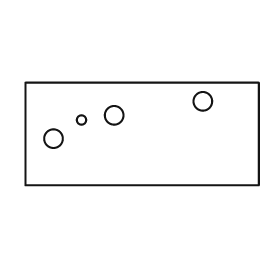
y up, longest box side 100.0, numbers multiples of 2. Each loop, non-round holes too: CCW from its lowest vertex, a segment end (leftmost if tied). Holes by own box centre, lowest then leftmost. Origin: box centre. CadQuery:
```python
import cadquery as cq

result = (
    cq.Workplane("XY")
    .moveTo(-50.0, -22.0)
    .lineTo(50.0, -22.0)
    .lineTo(50.0, 22.0)
    .lineTo(-50.0, 22.0)
    .close()
    .moveTo(-38.0, -2.0)
    .circle(4.0)
    .moveTo(-26.0, 6.0)
    .circle(2.0)
    .moveTo(-12.0, 8.0)
    .circle(4.0)
    .moveTo(26.0, 14.0)
    .circle(4.0)
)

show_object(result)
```